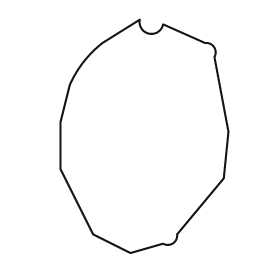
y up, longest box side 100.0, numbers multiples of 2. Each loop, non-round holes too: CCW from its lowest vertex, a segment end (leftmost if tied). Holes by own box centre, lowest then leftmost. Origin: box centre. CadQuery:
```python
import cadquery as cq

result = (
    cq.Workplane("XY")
    .moveTo(-6.0, -50.0)
    .lineTo(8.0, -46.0)
    .threePointArc((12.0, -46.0), (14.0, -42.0))
    .lineTo(34.0, -18.0)
    .lineTo(36.0, 2.0)
    .lineTo(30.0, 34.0)
    .threePointArc((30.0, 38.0), (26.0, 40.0))
    .lineTo(8.0, 48.0)
    .threePointArc((2.0, 44.0), (-2.0, 50.0))
    .lineTo(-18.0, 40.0)
    .threePointArc((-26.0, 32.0), (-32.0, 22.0))
    .lineTo(-36.0, 6.0)
    .lineTo(-36.0, -14.0)
    .lineTo(-22.0, -42.0)
    .close()
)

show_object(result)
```